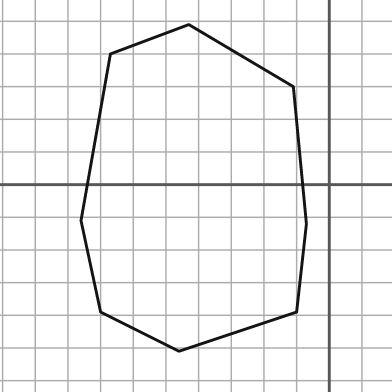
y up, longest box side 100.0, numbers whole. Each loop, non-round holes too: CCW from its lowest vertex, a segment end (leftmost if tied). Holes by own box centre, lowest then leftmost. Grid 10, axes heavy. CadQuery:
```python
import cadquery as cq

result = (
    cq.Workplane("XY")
    .moveTo(-46.0, -51.0)
    .lineTo(-10.0, -39.0)
    .lineTo(-7.0, -12.0)
    .lineTo(-11.0, 30.0)
    .lineTo(-43.0, 49.0)
    .lineTo(-67.0, 40.0)
    .lineTo(-76.0, -11.0)
    .lineTo(-70.0, -39.0)
    .close()
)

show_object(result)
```